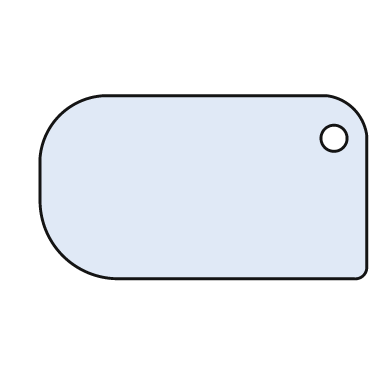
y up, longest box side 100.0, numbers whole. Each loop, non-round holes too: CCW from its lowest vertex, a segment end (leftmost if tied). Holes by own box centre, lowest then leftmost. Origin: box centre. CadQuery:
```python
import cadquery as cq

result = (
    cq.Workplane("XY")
    .moveTo(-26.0, -28.0)
    .lineTo(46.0, -28.0)
    .threePointArc((49.0, -27.0), (50.0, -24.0))
    .lineTo(50.0, 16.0)
    .threePointArc((46.0, 24.0), (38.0, 28.0))
    .lineTo(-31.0, 28.0)
    .threePointArc((-44.0, 22.0), (-50.0, 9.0))
    .lineTo(-50.0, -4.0)
    .threePointArc((-43.0, -21.0), (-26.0, -28.0))
    .close()
    .moveTo(40.0, 15.0)
    .circle(4.0)
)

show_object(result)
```